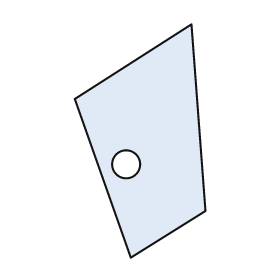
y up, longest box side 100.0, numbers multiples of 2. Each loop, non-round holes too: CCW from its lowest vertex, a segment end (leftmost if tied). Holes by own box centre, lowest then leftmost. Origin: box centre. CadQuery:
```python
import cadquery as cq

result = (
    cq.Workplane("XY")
    .moveTo(-4.0, -50.0)
    .lineTo(28.0, -30.0)
    .lineTo(22.0, 50.0)
    .lineTo(-28.0, 18.0)
    .close()
    .moveTo(-6.0, -10.0)
    .circle(6.0)
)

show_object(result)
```